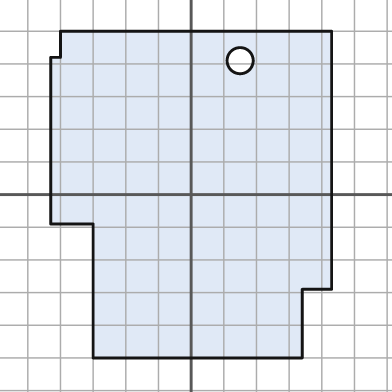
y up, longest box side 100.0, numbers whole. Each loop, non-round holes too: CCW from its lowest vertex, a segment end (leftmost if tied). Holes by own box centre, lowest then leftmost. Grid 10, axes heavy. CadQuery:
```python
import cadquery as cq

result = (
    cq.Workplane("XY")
    .moveTo(-30.0, -50.0)
    .lineTo(34.0, -50.0)
    .lineTo(34.0, -29.0)
    .lineTo(43.0, -29.0)
    .lineTo(43.0, 50.0)
    .lineTo(-40.0, 50.0)
    .lineTo(-40.0, 42.0)
    .lineTo(-43.0, 42.0)
    .lineTo(-43.0, -9.0)
    .lineTo(-30.0, -9.0)
    .close()
    .moveTo(15.0, 41.0)
    .circle(4.0)
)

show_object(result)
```